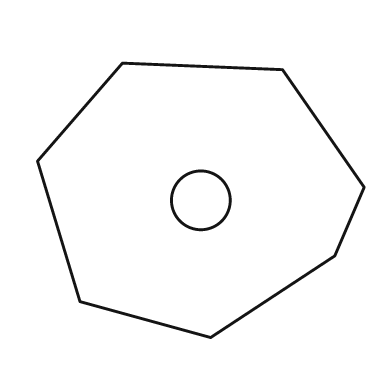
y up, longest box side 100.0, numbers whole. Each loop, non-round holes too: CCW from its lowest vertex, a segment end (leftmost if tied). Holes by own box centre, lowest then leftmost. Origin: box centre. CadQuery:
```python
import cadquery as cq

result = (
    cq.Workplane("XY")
    .moveTo(3.0, -42.0)
    .lineTo(41.0, -17.0)
    .lineTo(50.0, 4.0)
    .lineTo(25.0, 40.0)
    .lineTo(-24.0, 42.0)
    .lineTo(-50.0, 12.0)
    .lineTo(-37.0, -31.0)
    .close()
    .moveTo(0.0, 0.0)
    .circle(9.0)
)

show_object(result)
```